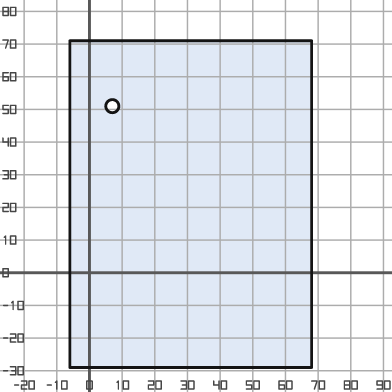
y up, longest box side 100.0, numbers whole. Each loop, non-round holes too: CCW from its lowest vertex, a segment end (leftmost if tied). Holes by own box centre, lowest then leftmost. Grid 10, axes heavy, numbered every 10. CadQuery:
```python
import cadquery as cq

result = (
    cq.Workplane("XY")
    .moveTo(-6.0, -29.0)
    .lineTo(68.0, -29.0)
    .lineTo(68.0, 71.0)
    .lineTo(-6.0, 71.0)
    .close()
    .moveTo(7.0, 51.0)
    .circle(2.0)
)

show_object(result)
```